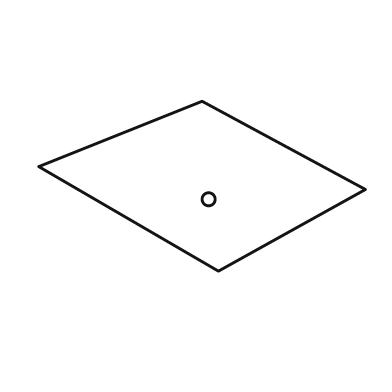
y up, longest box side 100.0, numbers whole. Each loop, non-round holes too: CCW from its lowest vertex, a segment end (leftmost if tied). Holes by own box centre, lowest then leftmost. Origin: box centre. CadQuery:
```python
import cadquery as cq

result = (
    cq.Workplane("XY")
    .moveTo(5.0, -26.0)
    .lineTo(50.0, -1.0)
    .lineTo(0.0, 26.0)
    .lineTo(-50.0, 6.0)
    .close()
    .moveTo(2.0, -4.0)
    .circle(2.0)
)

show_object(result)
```